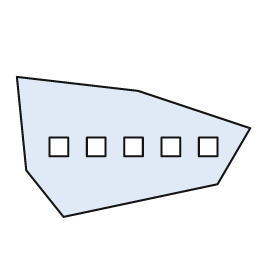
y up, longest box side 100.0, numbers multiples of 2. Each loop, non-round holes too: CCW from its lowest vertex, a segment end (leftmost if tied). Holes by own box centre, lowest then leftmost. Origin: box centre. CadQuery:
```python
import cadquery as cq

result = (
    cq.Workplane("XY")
    .moveTo(-30.0, -30.0)
    .lineTo(36.0, -16.0)
    .lineTo(50.0, 8.0)
    .lineTo(2.0, 24.0)
    .lineTo(-50.0, 30.0)
    .lineTo(-46.0, -10.0)
    .close()
    .moveTo(-36.0, -4.0)
    .lineTo(-28.0, -4.0)
    .lineTo(-28.0, 4.0)
    .lineTo(-36.0, 4.0)
    .close()
    .moveTo(-20.0, -4.0)
    .lineTo(-12.0, -4.0)
    .lineTo(-12.0, 4.0)
    .lineTo(-20.0, 4.0)
    .close()
    .moveTo(-4.0, -4.0)
    .lineTo(4.0, -4.0)
    .lineTo(4.0, 4.0)
    .lineTo(-4.0, 4.0)
    .close()
    .moveTo(12.0, -4.0)
    .lineTo(20.0, -4.0)
    .lineTo(20.0, 4.0)
    .lineTo(12.0, 4.0)
    .close()
    .moveTo(28.0, -4.0)
    .lineTo(36.0, -4.0)
    .lineTo(36.0, 4.0)
    .lineTo(28.0, 4.0)
    .close()
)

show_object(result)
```